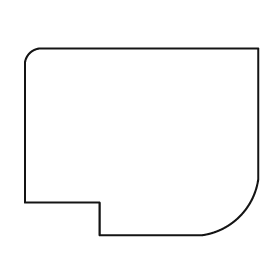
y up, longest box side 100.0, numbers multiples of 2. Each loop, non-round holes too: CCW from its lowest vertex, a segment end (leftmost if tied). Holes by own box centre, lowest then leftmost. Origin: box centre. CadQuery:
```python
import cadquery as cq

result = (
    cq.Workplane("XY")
    .moveTo(-18.0, -40.0)
    .lineTo(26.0, -40.0)
    .threePointArc((42.0, -32.0), (50.0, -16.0))
    .lineTo(50.0, 40.0)
    .lineTo(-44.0, 40.0)
    .threePointArc((-48.0, 38.0), (-50.0, 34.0))
    .lineTo(-50.0, -26.0)
    .lineTo(-18.0, -26.0)
    .close()
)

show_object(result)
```